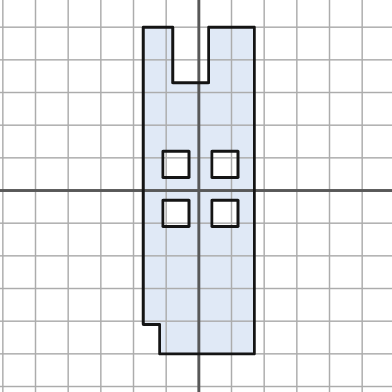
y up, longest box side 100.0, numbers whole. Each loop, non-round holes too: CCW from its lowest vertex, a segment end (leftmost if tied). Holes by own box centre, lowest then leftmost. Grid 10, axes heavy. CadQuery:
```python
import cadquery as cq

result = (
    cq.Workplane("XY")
    .moveTo(-12.0, -50.0)
    .lineTo(17.0, -50.0)
    .lineTo(17.0, 50.0)
    .lineTo(3.0, 50.0)
    .lineTo(3.0, 33.0)
    .lineTo(-8.0, 33.0)
    .lineTo(-8.0, 50.0)
    .lineTo(-17.0, 50.0)
    .lineTo(-17.0, -41.0)
    .lineTo(-12.0, -41.0)
    .close()
    .moveTo(-11.0, -11.0)
    .lineTo(-3.0, -11.0)
    .lineTo(-3.0, -3.0)
    .lineTo(-11.0, -3.0)
    .close()
    .moveTo(4.0, -11.0)
    .lineTo(12.0, -11.0)
    .lineTo(12.0, -3.0)
    .lineTo(4.0, -3.0)
    .close()
    .moveTo(-11.0, 4.0)
    .lineTo(-3.0, 4.0)
    .lineTo(-3.0, 12.0)
    .lineTo(-11.0, 12.0)
    .close()
    .moveTo(4.0, 4.0)
    .lineTo(12.0, 4.0)
    .lineTo(12.0, 12.0)
    .lineTo(4.0, 12.0)
    .close()
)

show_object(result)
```